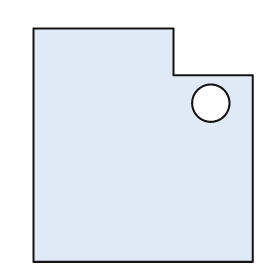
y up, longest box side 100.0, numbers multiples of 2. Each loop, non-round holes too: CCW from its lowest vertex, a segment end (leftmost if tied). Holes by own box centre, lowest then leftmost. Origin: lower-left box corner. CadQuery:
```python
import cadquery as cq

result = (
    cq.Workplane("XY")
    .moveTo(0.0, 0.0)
    .lineTo(94.0, 0.0)
    .lineTo(94.0, 80.0)
    .lineTo(60.0, 80.0)
    .lineTo(60.0, 100.0)
    .lineTo(0.0, 100.0)
    .close()
    .moveTo(76.0, 68.0)
    .circle(8.0)
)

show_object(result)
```